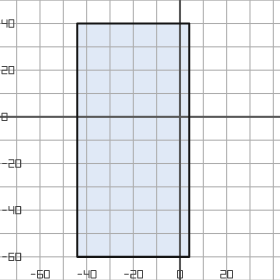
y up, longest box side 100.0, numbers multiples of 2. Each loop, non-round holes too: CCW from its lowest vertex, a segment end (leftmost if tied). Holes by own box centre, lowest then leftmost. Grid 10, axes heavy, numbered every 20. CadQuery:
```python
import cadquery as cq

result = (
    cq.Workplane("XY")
    .moveTo(-44.0, -60.0)
    .lineTo(4.0, -60.0)
    .lineTo(4.0, 40.0)
    .lineTo(-44.0, 40.0)
    .close()
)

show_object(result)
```